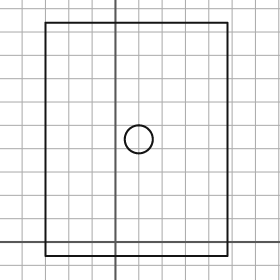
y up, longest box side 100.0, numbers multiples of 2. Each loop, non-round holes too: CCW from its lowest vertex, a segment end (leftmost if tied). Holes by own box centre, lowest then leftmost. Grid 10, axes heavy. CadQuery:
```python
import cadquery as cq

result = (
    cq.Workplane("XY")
    .moveTo(-30.0, -6.0)
    .lineTo(48.0, -6.0)
    .lineTo(48.0, 94.0)
    .lineTo(-30.0, 94.0)
    .close()
    .moveTo(10.0, 44.0)
    .circle(6.0)
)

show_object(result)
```